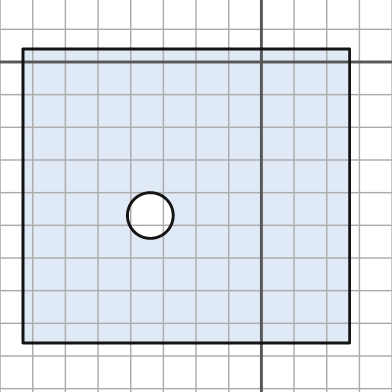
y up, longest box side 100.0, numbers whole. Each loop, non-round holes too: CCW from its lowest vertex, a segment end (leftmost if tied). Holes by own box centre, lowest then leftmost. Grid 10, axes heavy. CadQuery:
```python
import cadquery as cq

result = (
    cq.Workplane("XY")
    .moveTo(-73.0, -86.0)
    .lineTo(27.0, -86.0)
    .lineTo(27.0, 4.0)
    .lineTo(-73.0, 4.0)
    .close()
    .moveTo(-34.0, -47.0)
    .circle(7.0)
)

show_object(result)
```